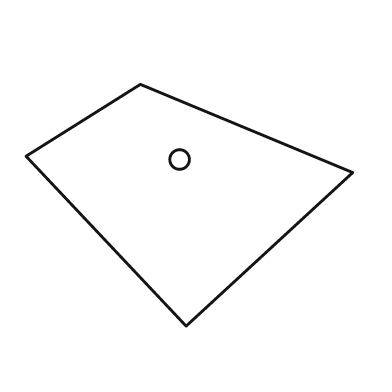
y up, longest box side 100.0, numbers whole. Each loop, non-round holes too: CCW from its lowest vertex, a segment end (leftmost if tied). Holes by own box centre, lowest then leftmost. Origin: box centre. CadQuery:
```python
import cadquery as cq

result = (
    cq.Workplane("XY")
    .moveTo(-1.0, -37.0)
    .lineTo(50.0, 10.0)
    .lineTo(-15.0, 37.0)
    .lineTo(-50.0, 15.0)
    .close()
    .moveTo(-3.0, 14.0)
    .circle(3.0)
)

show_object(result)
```